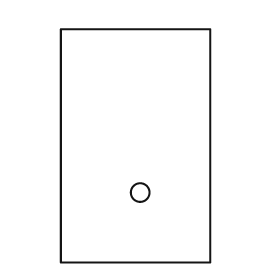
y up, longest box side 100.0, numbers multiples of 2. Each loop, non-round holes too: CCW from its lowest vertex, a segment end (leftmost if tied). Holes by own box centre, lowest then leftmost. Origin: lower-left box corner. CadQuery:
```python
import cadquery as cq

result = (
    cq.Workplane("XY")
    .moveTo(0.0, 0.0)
    .lineTo(64.0, 0.0)
    .lineTo(64.0, 100.0)
    .lineTo(0.0, 100.0)
    .close()
    .moveTo(34.0, 30.0)
    .circle(4.0)
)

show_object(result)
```